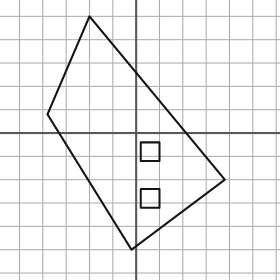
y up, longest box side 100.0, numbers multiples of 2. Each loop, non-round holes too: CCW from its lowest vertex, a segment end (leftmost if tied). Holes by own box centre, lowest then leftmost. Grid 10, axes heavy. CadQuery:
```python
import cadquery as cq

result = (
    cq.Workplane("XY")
    .moveTo(-2.0, -50.0)
    .lineTo(38.0, -20.0)
    .lineTo(-20.0, 50.0)
    .lineTo(-38.0, 8.0)
    .close()
    .moveTo(2.0, -32.0)
    .lineTo(10.0, -32.0)
    .lineTo(10.0, -24.0)
    .lineTo(2.0, -24.0)
    .close()
    .moveTo(2.0, -12.0)
    .lineTo(10.0, -12.0)
    .lineTo(10.0, -4.0)
    .lineTo(2.0, -4.0)
    .close()
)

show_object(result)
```